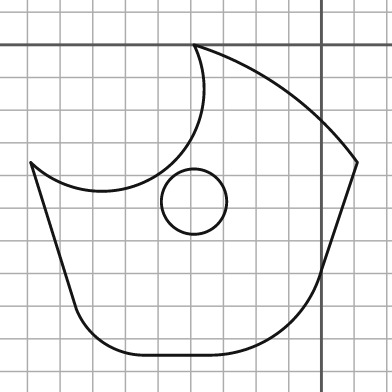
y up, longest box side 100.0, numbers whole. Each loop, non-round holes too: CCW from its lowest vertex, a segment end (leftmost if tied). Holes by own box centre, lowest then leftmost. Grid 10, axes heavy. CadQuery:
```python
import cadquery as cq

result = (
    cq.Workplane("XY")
    .moveTo(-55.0, -95.0)
    .lineTo(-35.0, -95.0)
    .threePointArc((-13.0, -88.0), (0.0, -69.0))
    .lineTo(11.0, -36.0)
    .threePointArc((-11.0, -14.0), (-39.0, 0.0))
    .threePointArc((-49.0, -39.0), (-89.0, -36.0))
    .lineTo(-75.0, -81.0)
    .threePointArc((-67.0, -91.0), (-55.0, -95.0))
    .close()
    .moveTo(-39.0, -48.0)
    .circle(10.0)
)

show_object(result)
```